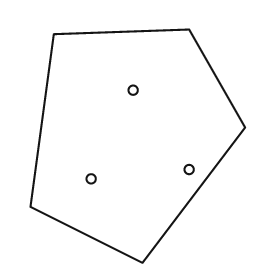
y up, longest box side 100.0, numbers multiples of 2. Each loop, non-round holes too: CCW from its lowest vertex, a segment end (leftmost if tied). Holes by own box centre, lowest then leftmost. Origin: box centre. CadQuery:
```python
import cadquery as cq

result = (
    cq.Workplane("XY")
    .moveTo(2.0, -50.0)
    .lineTo(46.0, 8.0)
    .lineTo(22.0, 50.0)
    .lineTo(-36.0, 48.0)
    .lineTo(-46.0, -26.0)
    .close()
    .moveTo(-20.0, -14.0)
    .circle(2.0)
    .moveTo(22.0, -10.0)
    .circle(2.0)
    .moveTo(-2.0, 24.0)
    .circle(2.0)
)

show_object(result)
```